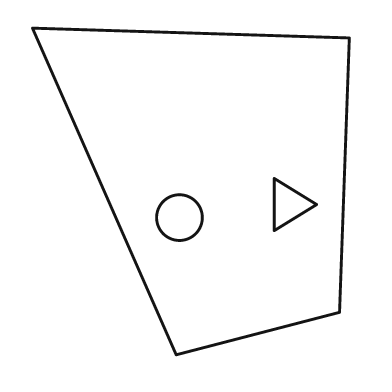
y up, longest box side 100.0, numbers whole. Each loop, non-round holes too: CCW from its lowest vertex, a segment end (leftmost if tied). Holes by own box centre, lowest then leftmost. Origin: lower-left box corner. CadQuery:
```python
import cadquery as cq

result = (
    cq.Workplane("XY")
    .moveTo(44.0, 0.0)
    .lineTo(94.0, 13.0)
    .lineTo(97.0, 97.0)
    .lineTo(0.0, 100.0)
    .close()
    .moveTo(45.0, 42.0)
    .circle(7.0)
    .moveTo(74.0, 38.0)
    .lineTo(87.0, 46.0)
    .lineTo(74.0, 54.0)
    .close()
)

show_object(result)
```